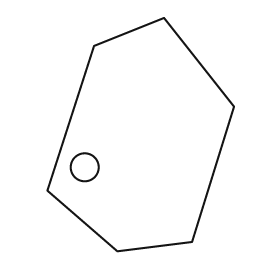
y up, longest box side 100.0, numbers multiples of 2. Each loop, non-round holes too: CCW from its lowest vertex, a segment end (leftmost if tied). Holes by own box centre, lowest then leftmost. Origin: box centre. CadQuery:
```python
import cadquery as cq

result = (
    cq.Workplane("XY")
    .moveTo(-10.0, -50.0)
    .lineTo(22.0, -46.0)
    .lineTo(40.0, 12.0)
    .lineTo(10.0, 50.0)
    .lineTo(-20.0, 38.0)
    .lineTo(-40.0, -24.0)
    .close()
    .moveTo(-24.0, -14.0)
    .circle(6.0)
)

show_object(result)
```